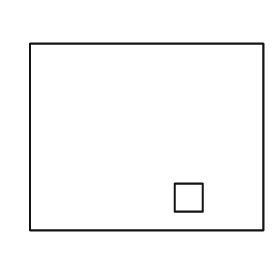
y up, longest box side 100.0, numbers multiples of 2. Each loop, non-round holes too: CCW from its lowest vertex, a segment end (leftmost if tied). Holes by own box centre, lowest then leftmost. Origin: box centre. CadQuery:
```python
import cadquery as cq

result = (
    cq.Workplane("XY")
    .moveTo(-50.0, -40.0)
    .lineTo(50.0, -40.0)
    .lineTo(50.0, 40.0)
    .lineTo(-50.0, 40.0)
    .close()
    .moveTo(12.0, -32.0)
    .lineTo(24.0, -32.0)
    .lineTo(24.0, -20.0)
    .lineTo(12.0, -20.0)
    .close()
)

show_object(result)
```